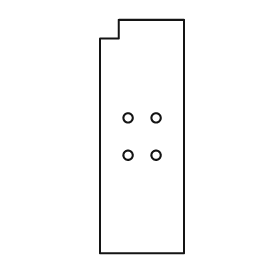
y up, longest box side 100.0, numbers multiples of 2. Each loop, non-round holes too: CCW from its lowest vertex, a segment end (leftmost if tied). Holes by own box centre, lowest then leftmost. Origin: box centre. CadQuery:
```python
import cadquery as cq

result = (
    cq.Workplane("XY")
    .moveTo(-18.0, -50.0)
    .lineTo(18.0, -50.0)
    .lineTo(18.0, 50.0)
    .lineTo(-10.0, 50.0)
    .lineTo(-10.0, 42.0)
    .lineTo(-18.0, 42.0)
    .close()
    .moveTo(-6.0, -8.0)
    .circle(2.0)
    .moveTo(6.0, -8.0)
    .circle(2.0)
    .moveTo(-6.0, 8.0)
    .circle(2.0)
    .moveTo(6.0, 8.0)
    .circle(2.0)
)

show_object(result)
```